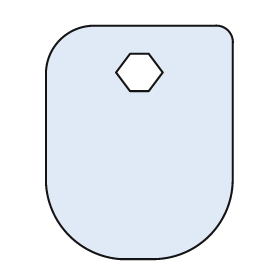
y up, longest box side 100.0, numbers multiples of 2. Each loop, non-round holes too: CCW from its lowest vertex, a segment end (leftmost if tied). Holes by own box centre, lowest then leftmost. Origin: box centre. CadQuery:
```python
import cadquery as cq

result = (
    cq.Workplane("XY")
    .moveTo(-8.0, -50.0)
    .lineTo(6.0, -50.0)
    .threePointArc((30.0, -40.0), (40.0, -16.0))
    .lineTo(40.0, 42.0)
    .threePointArc((38.0, 48.0), (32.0, 50.0))
    .lineTo(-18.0, 50.0)
    .threePointArc((-34.0, 44.0), (-40.0, 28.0))
    .lineTo(-40.0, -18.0)
    .threePointArc((-30.0, -40.0), (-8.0, -50.0))
    .close()
    .moveTo(-4.0, 22.0)
    .lineTo(4.0, 22.0)
    .lineTo(10.0, 30.0)
    .lineTo(4.0, 38.0)
    .lineTo(-4.0, 38.0)
    .lineTo(-10.0, 30.0)
    .close()
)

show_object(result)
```